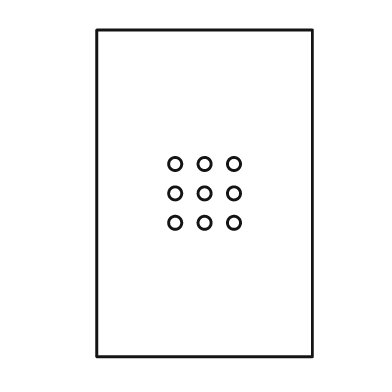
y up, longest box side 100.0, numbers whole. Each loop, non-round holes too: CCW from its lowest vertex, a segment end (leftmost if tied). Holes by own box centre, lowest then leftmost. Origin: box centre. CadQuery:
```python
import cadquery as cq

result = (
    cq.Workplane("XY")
    .moveTo(-33.0, -50.0)
    .lineTo(33.0, -50.0)
    .lineTo(33.0, 50.0)
    .lineTo(-33.0, 50.0)
    .close()
    .moveTo(-9.0, -9.0)
    .circle(2.0)
    .moveTo(0.0, -9.0)
    .circle(2.0)
    .moveTo(9.0, -9.0)
    .circle(2.0)
    .moveTo(-9.0, 0.0)
    .circle(2.0)
    .moveTo(0.0, 0.0)
    .circle(2.0)
    .moveTo(9.0, 0.0)
    .circle(2.0)
    .moveTo(-9.0, 9.0)
    .circle(2.0)
    .moveTo(0.0, 9.0)
    .circle(2.0)
    .moveTo(9.0, 9.0)
    .circle(2.0)
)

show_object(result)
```